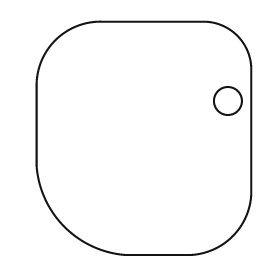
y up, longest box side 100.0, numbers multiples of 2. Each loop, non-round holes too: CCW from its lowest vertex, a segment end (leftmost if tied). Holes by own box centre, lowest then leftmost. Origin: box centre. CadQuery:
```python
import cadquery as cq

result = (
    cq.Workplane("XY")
    .moveTo(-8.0, -50.0)
    .lineTo(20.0, -50.0)
    .threePointArc((38.0, -42.0), (46.0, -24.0))
    .lineTo(46.0, 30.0)
    .threePointArc((40.0, 44.0), (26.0, 50.0))
    .lineTo(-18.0, 50.0)
    .threePointArc((-38.0, 42.0), (-46.0, 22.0))
    .lineTo(-46.0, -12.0)
    .threePointArc((-34.0, -38.0), (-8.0, -50.0))
    .close()
    .moveTo(36.0, 16.0)
    .circle(6.0)
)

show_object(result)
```